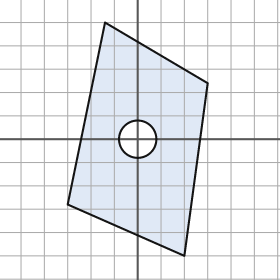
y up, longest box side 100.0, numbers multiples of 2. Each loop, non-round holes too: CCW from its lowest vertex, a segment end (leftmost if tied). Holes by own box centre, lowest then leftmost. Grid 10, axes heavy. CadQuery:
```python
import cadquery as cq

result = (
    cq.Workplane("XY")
    .moveTo(20.0, -50.0)
    .lineTo(30.0, 24.0)
    .lineTo(-14.0, 50.0)
    .lineTo(-30.0, -28.0)
    .close()
    .moveTo(0.0, 0.0)
    .circle(8.0)
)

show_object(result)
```